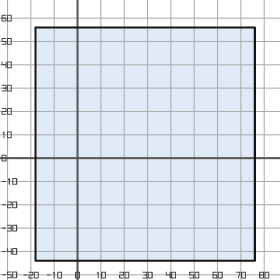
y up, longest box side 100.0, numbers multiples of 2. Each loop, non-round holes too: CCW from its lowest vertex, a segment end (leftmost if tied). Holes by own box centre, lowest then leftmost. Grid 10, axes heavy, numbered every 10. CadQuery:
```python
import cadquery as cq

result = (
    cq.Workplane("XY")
    .moveTo(-18.0, -44.0)
    .lineTo(76.0, -44.0)
    .lineTo(76.0, 56.0)
    .lineTo(-18.0, 56.0)
    .close()
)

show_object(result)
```